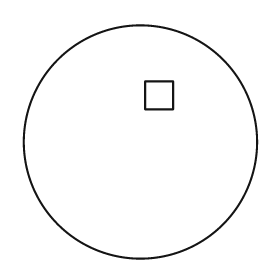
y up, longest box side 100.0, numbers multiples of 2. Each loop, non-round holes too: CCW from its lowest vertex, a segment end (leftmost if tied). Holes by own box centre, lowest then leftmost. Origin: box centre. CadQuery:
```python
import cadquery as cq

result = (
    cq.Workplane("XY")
    .moveTo(0.0, 0.0)
    .circle(50.0)
    .moveTo(2.0, 14.0)
    .lineTo(14.0, 14.0)
    .lineTo(14.0, 26.0)
    .lineTo(2.0, 26.0)
    .close()
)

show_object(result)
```